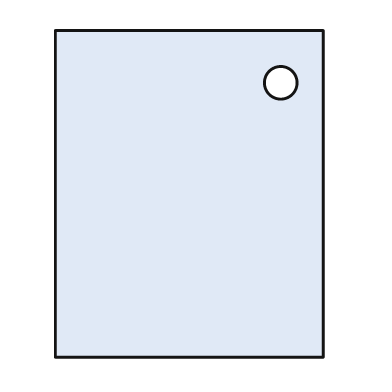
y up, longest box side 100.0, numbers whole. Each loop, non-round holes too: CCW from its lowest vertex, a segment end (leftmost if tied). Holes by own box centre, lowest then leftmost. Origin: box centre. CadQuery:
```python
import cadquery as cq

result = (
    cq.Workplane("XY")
    .moveTo(-41.0, -50.0)
    .lineTo(41.0, -50.0)
    .lineTo(41.0, 50.0)
    .lineTo(-41.0, 50.0)
    .close()
    .moveTo(28.0, 34.0)
    .circle(5.0)
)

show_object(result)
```